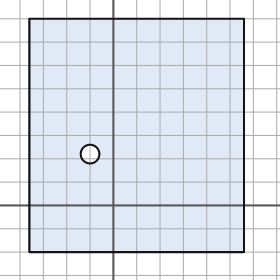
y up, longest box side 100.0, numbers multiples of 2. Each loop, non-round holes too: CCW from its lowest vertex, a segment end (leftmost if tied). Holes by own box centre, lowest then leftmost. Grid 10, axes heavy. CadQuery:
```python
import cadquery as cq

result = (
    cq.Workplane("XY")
    .moveTo(-36.0, -20.0)
    .lineTo(56.0, -20.0)
    .lineTo(56.0, 80.0)
    .lineTo(-36.0, 80.0)
    .close()
    .moveTo(-10.0, 22.0)
    .circle(4.0)
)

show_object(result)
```